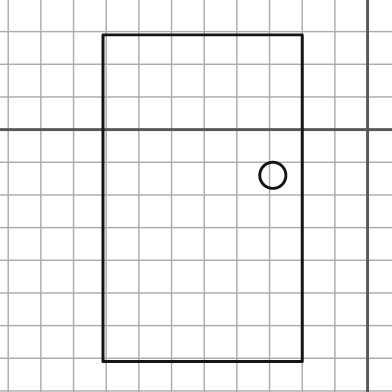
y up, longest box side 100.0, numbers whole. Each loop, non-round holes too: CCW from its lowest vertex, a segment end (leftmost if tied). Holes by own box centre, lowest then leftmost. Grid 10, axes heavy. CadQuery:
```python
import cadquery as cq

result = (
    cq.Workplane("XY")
    .moveTo(-81.0, -71.0)
    .lineTo(-20.0, -71.0)
    .lineTo(-20.0, 29.0)
    .lineTo(-81.0, 29.0)
    .close()
    .moveTo(-29.0, -14.0)
    .circle(4.0)
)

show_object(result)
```